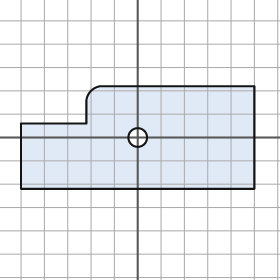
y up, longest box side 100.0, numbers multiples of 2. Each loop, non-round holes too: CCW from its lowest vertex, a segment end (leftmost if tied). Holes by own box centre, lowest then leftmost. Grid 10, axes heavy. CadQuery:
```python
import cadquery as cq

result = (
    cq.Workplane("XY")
    .moveTo(-50.0, -22.0)
    .lineTo(50.0, -22.0)
    .lineTo(50.0, 22.0)
    .lineTo(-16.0, 22.0)
    .threePointArc((-20.0, 20.0), (-22.0, 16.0))
    .lineTo(-22.0, 6.0)
    .lineTo(-50.0, 6.0)
    .close()
    .moveTo(0.0, 0.0)
    .circle(4.0)
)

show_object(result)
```